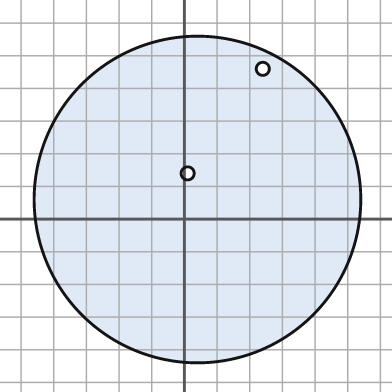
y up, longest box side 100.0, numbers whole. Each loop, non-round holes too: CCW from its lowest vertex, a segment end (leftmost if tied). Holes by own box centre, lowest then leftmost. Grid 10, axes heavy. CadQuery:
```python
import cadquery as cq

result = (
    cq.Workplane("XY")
    .moveTo(4.0, 6.0)
    .circle(50.0)
    .moveTo(1.0, 14.0)
    .circle(2.0)
    .moveTo(24.0, 46.0)
    .circle(2.0)
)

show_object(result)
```